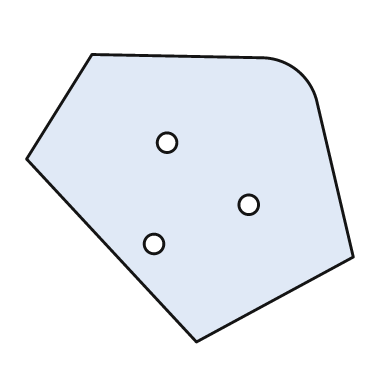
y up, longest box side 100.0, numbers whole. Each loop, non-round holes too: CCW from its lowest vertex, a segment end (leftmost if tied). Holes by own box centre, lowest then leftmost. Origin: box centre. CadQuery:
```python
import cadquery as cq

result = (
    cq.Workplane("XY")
    .moveTo(2.0, -44.0)
    .lineTo(50.0, -18.0)
    .lineTo(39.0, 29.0)
    .threePointArc((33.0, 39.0), (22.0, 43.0))
    .lineTo(-30.0, 44.0)
    .lineTo(-50.0, 12.0)
    .close()
    .moveTo(-11.0, -14.0)
    .circle(3.0)
    .moveTo(18.0, -2.0)
    .circle(3.0)
    .moveTo(-7.0, 17.0)
    .circle(3.0)
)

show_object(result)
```